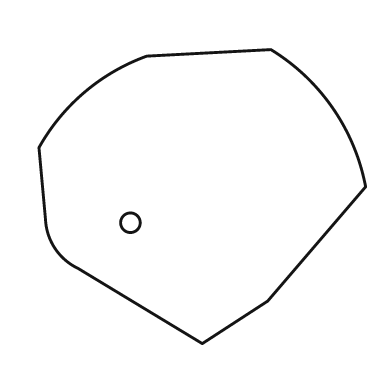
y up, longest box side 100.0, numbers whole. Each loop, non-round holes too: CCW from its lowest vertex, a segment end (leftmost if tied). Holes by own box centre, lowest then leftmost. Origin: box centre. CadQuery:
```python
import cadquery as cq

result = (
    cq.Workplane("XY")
    .moveTo(0.0, -45.0)
    .lineTo(20.0, -32.0)
    .lineTo(50.0, 3.0)
    .threePointArc((40.0, 27.0), (21.0, 45.0))
    .lineTo(-17.0, 43.0)
    .threePointArc((-36.0, 32.0), (-50.0, 15.0))
    .lineTo(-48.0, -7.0)
    .threePointArc((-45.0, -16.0), (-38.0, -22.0))
    .close()
    .moveTo(-22.0, -8.0)
    .circle(3.0)
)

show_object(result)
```